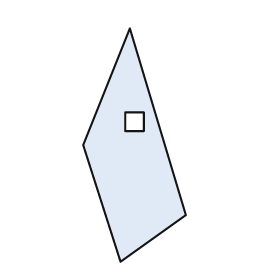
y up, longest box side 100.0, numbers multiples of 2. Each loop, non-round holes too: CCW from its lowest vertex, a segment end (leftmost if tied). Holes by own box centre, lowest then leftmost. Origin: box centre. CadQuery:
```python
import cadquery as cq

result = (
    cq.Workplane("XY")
    .moveTo(-6.0, -50.0)
    .lineTo(22.0, -30.0)
    .lineTo(-2.0, 50.0)
    .lineTo(-22.0, 0.0)
    .close()
    .moveTo(-4.0, 6.0)
    .lineTo(4.0, 6.0)
    .lineTo(4.0, 14.0)
    .lineTo(-4.0, 14.0)
    .close()
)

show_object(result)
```